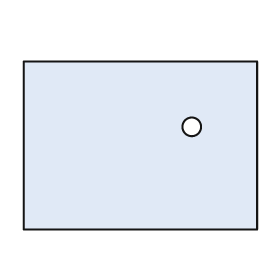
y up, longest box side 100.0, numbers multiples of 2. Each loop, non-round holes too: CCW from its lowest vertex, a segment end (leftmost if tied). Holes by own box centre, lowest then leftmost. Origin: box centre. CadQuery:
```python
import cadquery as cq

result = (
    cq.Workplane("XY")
    .moveTo(-50.0, -36.0)
    .lineTo(50.0, -36.0)
    .lineTo(50.0, 36.0)
    .lineTo(-50.0, 36.0)
    .close()
    .moveTo(22.0, 8.0)
    .circle(4.0)
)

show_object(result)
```